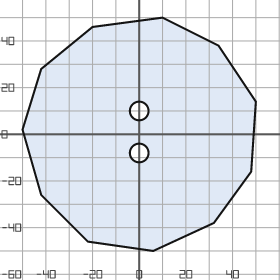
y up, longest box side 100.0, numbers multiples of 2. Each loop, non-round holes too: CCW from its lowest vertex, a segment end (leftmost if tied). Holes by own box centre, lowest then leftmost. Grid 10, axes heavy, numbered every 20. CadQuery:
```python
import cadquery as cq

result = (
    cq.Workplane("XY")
    .moveTo(6.0, -50.0)
    .lineTo(32.0, -38.0)
    .lineTo(48.0, -16.0)
    .lineTo(50.0, 14.0)
    .lineTo(34.0, 38.0)
    .lineTo(10.0, 50.0)
    .lineTo(-20.0, 46.0)
    .lineTo(-42.0, 28.0)
    .lineTo(-50.0, 2.0)
    .lineTo(-42.0, -26.0)
    .lineTo(-22.0, -46.0)
    .close()
    .moveTo(0.0, -8.0)
    .circle(4.0)
    .moveTo(0.0, 10.0)
    .circle(4.0)
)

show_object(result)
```